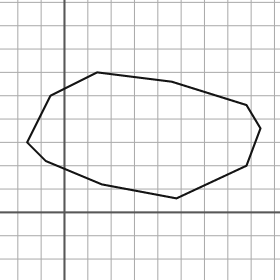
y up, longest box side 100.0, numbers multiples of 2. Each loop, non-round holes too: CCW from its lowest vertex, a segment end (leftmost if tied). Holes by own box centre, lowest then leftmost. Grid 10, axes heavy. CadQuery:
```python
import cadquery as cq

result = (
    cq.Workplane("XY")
    .moveTo(48.0, 6.0)
    .lineTo(78.0, 20.0)
    .lineTo(84.0, 36.0)
    .lineTo(78.0, 46.0)
    .lineTo(46.0, 56.0)
    .lineTo(14.0, 60.0)
    .lineTo(-6.0, 50.0)
    .lineTo(-16.0, 30.0)
    .lineTo(-8.0, 22.0)
    .lineTo(16.0, 12.0)
    .close()
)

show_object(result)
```